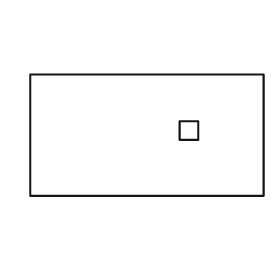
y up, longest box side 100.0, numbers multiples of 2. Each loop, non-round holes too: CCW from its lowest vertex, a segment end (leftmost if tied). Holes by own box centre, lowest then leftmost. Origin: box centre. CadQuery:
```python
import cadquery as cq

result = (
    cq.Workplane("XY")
    .moveTo(-50.0, -26.0)
    .lineTo(50.0, -26.0)
    .lineTo(50.0, 26.0)
    .lineTo(-50.0, 26.0)
    .close()
    .moveTo(14.0, -2.0)
    .lineTo(22.0, -2.0)
    .lineTo(22.0, 6.0)
    .lineTo(14.0, 6.0)
    .close()
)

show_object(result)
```